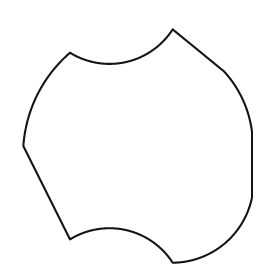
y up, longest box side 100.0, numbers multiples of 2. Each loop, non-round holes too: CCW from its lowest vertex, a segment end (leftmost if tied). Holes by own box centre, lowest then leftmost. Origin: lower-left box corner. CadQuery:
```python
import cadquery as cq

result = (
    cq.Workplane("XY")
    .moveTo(64.0, 0.0)
    .threePointArc((86.0, 8.0), (98.0, 28.0))
    .lineTo(98.0, 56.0)
    .threePointArc((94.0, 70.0), (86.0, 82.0))
    .lineTo(64.0, 100.0)
    .threePointArc((44.0, 86.0), (20.0, 90.0))
    .threePointArc((6.0, 72.0), (0.0, 50.0))
    .lineTo(20.0, 10.0)
    .threePointArc((44.0, 14.0), (64.0, 0.0))
    .close()
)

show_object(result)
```